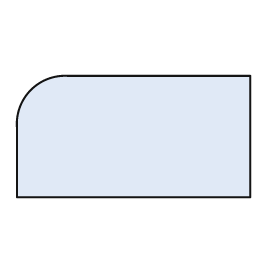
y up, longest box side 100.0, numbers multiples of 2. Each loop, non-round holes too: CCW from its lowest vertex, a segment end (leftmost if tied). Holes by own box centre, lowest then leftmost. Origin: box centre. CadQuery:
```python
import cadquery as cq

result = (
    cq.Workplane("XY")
    .moveTo(-50.0, -26.0)
    .lineTo(50.0, -26.0)
    .lineTo(50.0, 26.0)
    .lineTo(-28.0, 26.0)
    .threePointArc((-44.0, 20.0), (-50.0, 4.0))
    .close()
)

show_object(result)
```